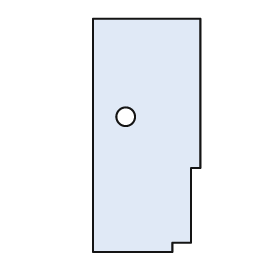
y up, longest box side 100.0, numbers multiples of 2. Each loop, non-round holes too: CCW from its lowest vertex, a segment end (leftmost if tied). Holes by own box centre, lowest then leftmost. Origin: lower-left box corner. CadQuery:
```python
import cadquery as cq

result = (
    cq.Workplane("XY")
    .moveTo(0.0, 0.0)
    .lineTo(34.0, 0.0)
    .lineTo(34.0, 4.0)
    .lineTo(42.0, 4.0)
    .lineTo(42.0, 36.0)
    .lineTo(46.0, 36.0)
    .lineTo(46.0, 100.0)
    .lineTo(0.0, 100.0)
    .close()
    .moveTo(14.0, 58.0)
    .circle(4.0)
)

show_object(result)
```